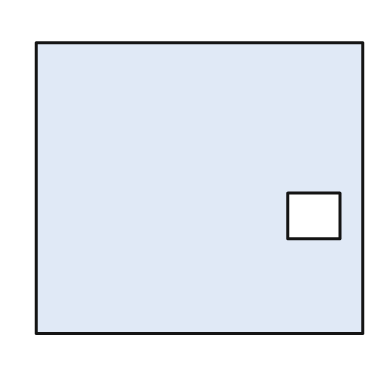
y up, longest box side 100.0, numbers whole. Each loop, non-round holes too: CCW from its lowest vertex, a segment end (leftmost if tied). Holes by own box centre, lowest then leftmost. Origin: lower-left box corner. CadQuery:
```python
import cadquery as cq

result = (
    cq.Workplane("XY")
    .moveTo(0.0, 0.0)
    .lineTo(100.0, 0.0)
    .lineTo(100.0, 89.0)
    .lineTo(0.0, 89.0)
    .close()
    .moveTo(77.0, 29.0)
    .lineTo(93.0, 29.0)
    .lineTo(93.0, 43.0)
    .lineTo(77.0, 43.0)
    .close()
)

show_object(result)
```